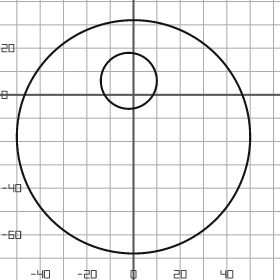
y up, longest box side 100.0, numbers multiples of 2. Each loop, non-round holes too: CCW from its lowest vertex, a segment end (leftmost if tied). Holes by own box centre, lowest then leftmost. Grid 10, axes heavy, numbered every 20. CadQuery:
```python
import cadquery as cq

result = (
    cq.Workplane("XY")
    .moveTo(0.0, -18.0)
    .circle(50.0)
    .moveTo(-2.0, 6.0)
    .circle(12.0)
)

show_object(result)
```